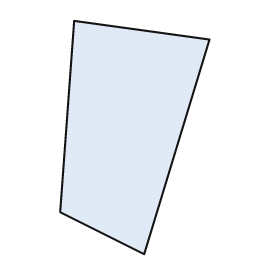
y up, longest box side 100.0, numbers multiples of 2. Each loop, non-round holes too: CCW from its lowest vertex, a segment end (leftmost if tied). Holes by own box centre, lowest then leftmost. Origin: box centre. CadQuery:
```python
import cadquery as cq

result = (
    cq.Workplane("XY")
    .moveTo(4.0, -50.0)
    .lineTo(32.0, 42.0)
    .lineTo(-26.0, 50.0)
    .lineTo(-32.0, -32.0)
    .close()
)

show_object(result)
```